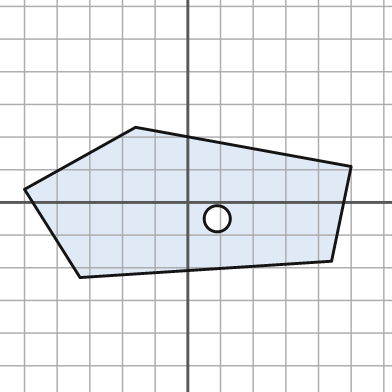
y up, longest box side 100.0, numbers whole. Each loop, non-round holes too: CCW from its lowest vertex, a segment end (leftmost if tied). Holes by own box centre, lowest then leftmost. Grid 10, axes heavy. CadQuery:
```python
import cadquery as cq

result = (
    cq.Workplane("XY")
    .moveTo(-33.0, -23.0)
    .lineTo(44.0, -18.0)
    .lineTo(50.0, 11.0)
    .lineTo(-16.0, 23.0)
    .lineTo(-50.0, 4.0)
    .close()
    .moveTo(9.0, -5.0)
    .circle(4.0)
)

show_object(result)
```